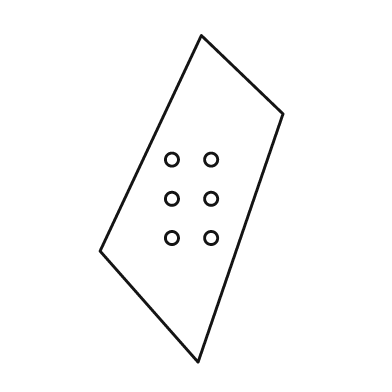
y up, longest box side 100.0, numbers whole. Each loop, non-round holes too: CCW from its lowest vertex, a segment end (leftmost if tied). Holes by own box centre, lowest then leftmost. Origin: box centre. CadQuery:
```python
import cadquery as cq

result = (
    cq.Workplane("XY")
    .moveTo(2.0, -50.0)
    .lineTo(28.0, 26.0)
    .lineTo(3.0, 50.0)
    .lineTo(-28.0, -16.0)
    .close()
    .moveTo(-6.0, -12.0)
    .circle(2.0)
    .moveTo(6.0, -12.0)
    .circle(2.0)
    .moveTo(-6.0, 0.0)
    .circle(2.0)
    .moveTo(6.0, 0.0)
    .circle(2.0)
    .moveTo(-6.0, 12.0)
    .circle(2.0)
    .moveTo(6.0, 12.0)
    .circle(2.0)
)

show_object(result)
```